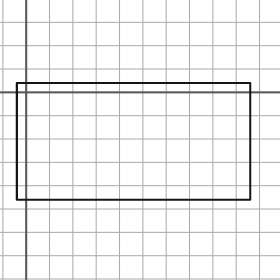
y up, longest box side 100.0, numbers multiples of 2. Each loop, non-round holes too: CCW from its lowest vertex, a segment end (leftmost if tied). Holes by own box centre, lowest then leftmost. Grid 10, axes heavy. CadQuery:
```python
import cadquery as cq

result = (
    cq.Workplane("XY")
    .moveTo(-4.0, -46.0)
    .lineTo(96.0, -46.0)
    .lineTo(96.0, 4.0)
    .lineTo(-4.0, 4.0)
    .close()
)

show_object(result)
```